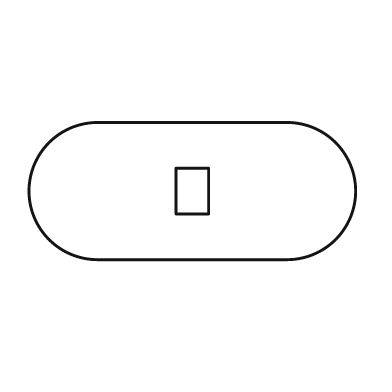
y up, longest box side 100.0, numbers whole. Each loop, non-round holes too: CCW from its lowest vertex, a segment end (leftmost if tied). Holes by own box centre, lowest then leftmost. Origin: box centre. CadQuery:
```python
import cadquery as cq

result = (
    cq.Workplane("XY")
    .moveTo(-29.0, -21.0)
    .lineTo(29.0, -21.0)
    .threePointArc((50.0, 0.0), (29.0, 21.0))
    .lineTo(-29.0, 21.0)
    .threePointArc((-50.0, 0.0), (-29.0, -21.0))
    .close()
    .moveTo(-5.0, -7.0)
    .lineTo(5.0, -7.0)
    .lineTo(5.0, 7.0)
    .lineTo(-5.0, 7.0)
    .close()
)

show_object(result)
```